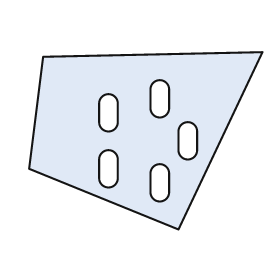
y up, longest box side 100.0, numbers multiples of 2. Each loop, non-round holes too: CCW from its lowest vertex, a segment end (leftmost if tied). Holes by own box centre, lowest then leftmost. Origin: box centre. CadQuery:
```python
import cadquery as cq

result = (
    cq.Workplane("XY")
    .moveTo(14.0, -38.0)
    .lineTo(50.0, 38.0)
    .lineTo(-44.0, 36.0)
    .lineTo(-50.0, -12.0)
    .close()
    .moveTo(2.0, -22.0)
    .threePointArc((6.0, -26.0), (10.0, -22.0))
    .lineTo(10.0, -14.0)
    .threePointArc((6.0, -10.0), (2.0, -14.0))
    .close()
    .moveTo(-20.0, -16.0)
    .threePointArc((-16.0, -20.0), (-12.0, -16.0))
    .lineTo(-12.0, -8.0)
    .threePointArc((-16.0, -4.0), (-20.0, -8.0))
    .close()
    .moveTo(14.0, -4.0)
    .threePointArc((18.0, -8.0), (22.0, -4.0))
    .lineTo(22.0, 4.0)
    .threePointArc((18.0, 8.0), (14.0, 4.0))
    .close()
    .moveTo(-20.0, 8.0)
    .threePointArc((-16.0, 4.0), (-12.0, 8.0))
    .lineTo(-12.0, 16.0)
    .threePointArc((-16.0, 20.0), (-20.0, 16.0))
    .close()
    .moveTo(2.0, 14.0)
    .threePointArc((6.0, 10.0), (10.0, 14.0))
    .lineTo(10.0, 22.0)
    .threePointArc((6.0, 26.0), (2.0, 22.0))
    .close()
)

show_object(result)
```